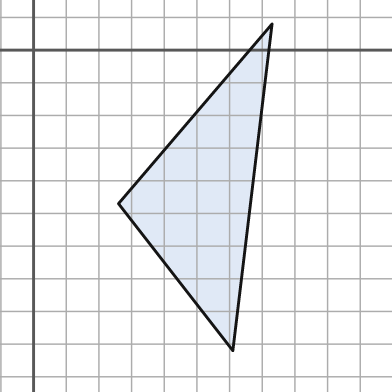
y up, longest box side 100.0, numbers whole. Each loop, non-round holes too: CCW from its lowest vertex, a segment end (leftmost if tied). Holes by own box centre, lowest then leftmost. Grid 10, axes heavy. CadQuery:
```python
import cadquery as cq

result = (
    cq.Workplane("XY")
    .moveTo(61.0, -92.0)
    .lineTo(73.0, 8.0)
    .lineTo(26.0, -47.0)
    .close()
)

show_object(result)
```